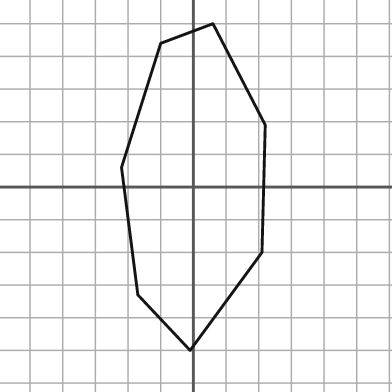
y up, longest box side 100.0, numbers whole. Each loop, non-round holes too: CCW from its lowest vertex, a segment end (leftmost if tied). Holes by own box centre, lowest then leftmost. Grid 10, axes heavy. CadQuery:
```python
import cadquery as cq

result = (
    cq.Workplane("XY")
    .moveTo(-1.0, -50.0)
    .lineTo(21.0, -20.0)
    .lineTo(22.0, 19.0)
    .lineTo(6.0, 50.0)
    .lineTo(-10.0, 44.0)
    .lineTo(-22.0, 6.0)
    .lineTo(-17.0, -33.0)
    .close()
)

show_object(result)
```